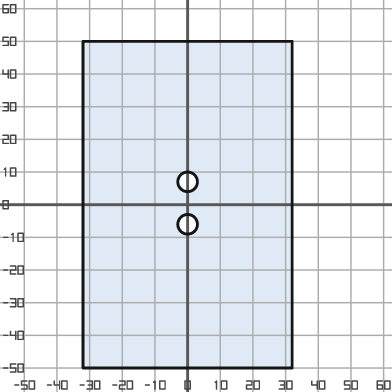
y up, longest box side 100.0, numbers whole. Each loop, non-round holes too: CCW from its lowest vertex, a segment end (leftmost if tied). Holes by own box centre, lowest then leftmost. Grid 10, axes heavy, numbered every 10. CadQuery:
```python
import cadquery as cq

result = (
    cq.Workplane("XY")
    .moveTo(-32.0, -50.0)
    .lineTo(32.0, -50.0)
    .lineTo(32.0, 50.0)
    .lineTo(-32.0, 50.0)
    .close()
    .moveTo(0.0, -6.0)
    .circle(3.0)
    .moveTo(0.0, 7.0)
    .circle(3.0)
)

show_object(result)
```